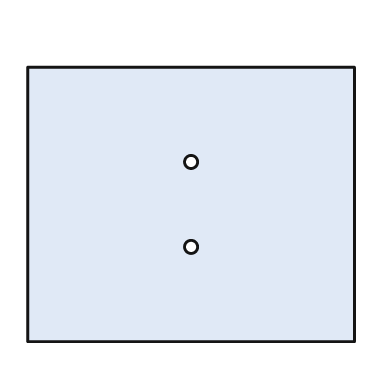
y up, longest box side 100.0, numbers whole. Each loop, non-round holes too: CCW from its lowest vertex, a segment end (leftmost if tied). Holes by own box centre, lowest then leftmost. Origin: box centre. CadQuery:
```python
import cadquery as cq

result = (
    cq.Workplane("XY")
    .moveTo(-50.0, -42.0)
    .lineTo(50.0, -42.0)
    .lineTo(50.0, 42.0)
    .lineTo(-50.0, 42.0)
    .close()
    .moveTo(0.0, -13.0)
    .circle(2.0)
    .moveTo(0.0, 13.0)
    .circle(2.0)
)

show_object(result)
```